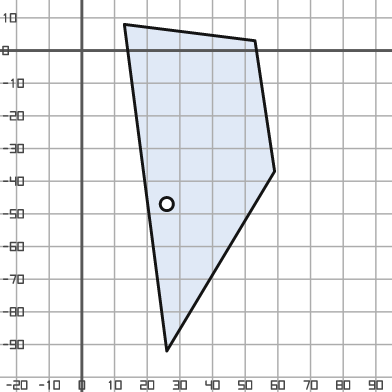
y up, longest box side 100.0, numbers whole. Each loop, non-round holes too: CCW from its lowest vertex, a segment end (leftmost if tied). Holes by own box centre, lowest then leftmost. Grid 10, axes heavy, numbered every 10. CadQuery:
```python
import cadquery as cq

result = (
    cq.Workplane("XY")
    .moveTo(26.0, -92.0)
    .lineTo(59.0, -37.0)
    .lineTo(53.0, 3.0)
    .lineTo(13.0, 8.0)
    .close()
    .moveTo(26.0, -47.0)
    .circle(2.0)
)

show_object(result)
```